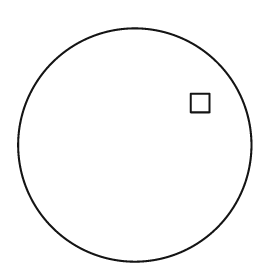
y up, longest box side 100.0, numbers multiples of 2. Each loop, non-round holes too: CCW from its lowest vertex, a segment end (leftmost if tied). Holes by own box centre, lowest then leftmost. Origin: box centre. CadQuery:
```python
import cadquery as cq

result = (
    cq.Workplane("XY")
    .moveTo(0.0, 0.0)
    .circle(50.0)
    .moveTo(24.0, 14.0)
    .lineTo(32.0, 14.0)
    .lineTo(32.0, 22.0)
    .lineTo(24.0, 22.0)
    .close()
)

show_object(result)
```